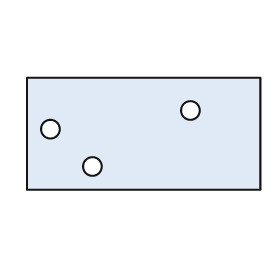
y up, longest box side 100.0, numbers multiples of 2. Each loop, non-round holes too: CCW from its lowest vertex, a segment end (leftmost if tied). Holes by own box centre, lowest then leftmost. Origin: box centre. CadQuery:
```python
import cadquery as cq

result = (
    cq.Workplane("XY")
    .moveTo(-50.0, -24.0)
    .lineTo(50.0, -24.0)
    .lineTo(50.0, 24.0)
    .lineTo(-50.0, 24.0)
    .close()
    .moveTo(-22.0, -14.0)
    .circle(4.0)
    .moveTo(-40.0, 2.0)
    .circle(4.0)
    .moveTo(20.0, 10.0)
    .circle(4.0)
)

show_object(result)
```